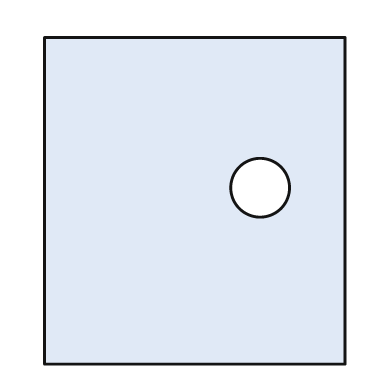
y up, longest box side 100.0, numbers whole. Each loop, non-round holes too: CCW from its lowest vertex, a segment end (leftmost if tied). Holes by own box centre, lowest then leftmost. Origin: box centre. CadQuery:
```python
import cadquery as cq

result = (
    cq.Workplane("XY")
    .moveTo(-46.0, -50.0)
    .lineTo(46.0, -50.0)
    .lineTo(46.0, 50.0)
    .lineTo(-46.0, 50.0)
    .close()
    .moveTo(20.0, 4.0)
    .circle(9.0)
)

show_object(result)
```